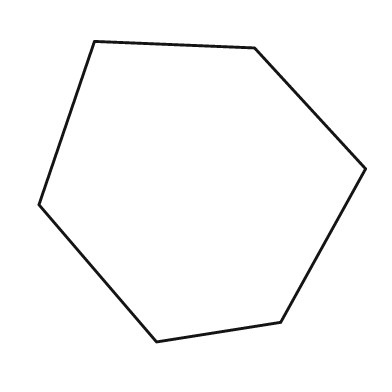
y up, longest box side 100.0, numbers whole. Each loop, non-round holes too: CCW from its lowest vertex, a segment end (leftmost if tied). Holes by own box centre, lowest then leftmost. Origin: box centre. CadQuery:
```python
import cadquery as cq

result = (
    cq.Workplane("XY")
    .moveTo(-14.0, -46.0)
    .lineTo(24.0, -40.0)
    .lineTo(50.0, 7.0)
    .lineTo(16.0, 44.0)
    .lineTo(-33.0, 46.0)
    .lineTo(-50.0, -4.0)
    .close()
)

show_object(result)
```